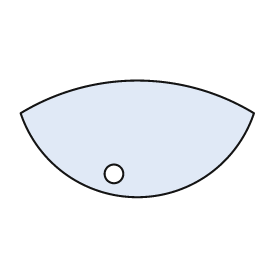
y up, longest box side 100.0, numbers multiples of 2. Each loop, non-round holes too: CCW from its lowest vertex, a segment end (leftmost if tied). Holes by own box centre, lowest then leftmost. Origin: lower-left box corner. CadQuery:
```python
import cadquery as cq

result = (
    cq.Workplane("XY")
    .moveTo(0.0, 36.0)
    .threePointArc((50.0, 0.0), (100.0, 36.0))
    .threePointArc((50.0, 50.0), (0.0, 36.0))
    .close()
    .moveTo(40.0, 10.0)
    .circle(4.0)
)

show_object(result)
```